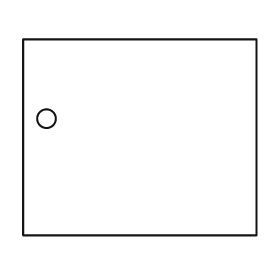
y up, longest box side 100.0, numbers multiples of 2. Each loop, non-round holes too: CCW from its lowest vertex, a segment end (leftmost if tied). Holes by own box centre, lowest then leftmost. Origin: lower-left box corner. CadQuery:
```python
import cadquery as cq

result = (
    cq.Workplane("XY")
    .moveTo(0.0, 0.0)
    .lineTo(100.0, 0.0)
    .lineTo(100.0, 84.0)
    .lineTo(0.0, 84.0)
    .close()
    .moveTo(10.0, 50.0)
    .circle(4.0)
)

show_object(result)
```